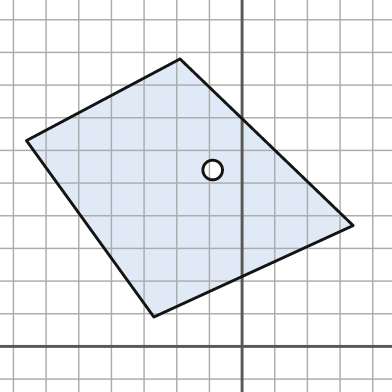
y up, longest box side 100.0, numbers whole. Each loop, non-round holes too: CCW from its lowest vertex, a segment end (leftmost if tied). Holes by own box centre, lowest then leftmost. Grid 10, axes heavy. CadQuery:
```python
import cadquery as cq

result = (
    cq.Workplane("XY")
    .moveTo(-27.0, 9.0)
    .lineTo(34.0, 37.0)
    .lineTo(-19.0, 88.0)
    .lineTo(-66.0, 63.0)
    .close()
    .moveTo(-9.0, 54.0)
    .circle(3.0)
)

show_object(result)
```